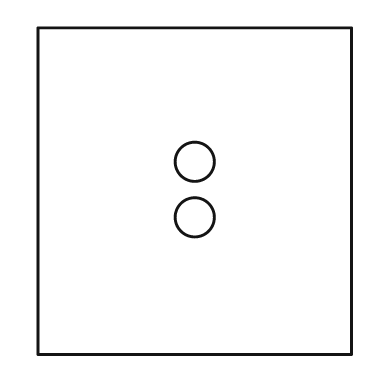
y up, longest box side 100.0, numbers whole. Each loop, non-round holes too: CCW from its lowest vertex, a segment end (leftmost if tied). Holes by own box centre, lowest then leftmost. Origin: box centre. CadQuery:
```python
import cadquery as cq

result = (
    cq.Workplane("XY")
    .moveTo(-48.0, -50.0)
    .lineTo(48.0, -50.0)
    .lineTo(48.0, 50.0)
    .lineTo(-48.0, 50.0)
    .close()
    .moveTo(0.0, -8.0)
    .circle(6.0)
    .moveTo(0.0, 9.0)
    .circle(6.0)
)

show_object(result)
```